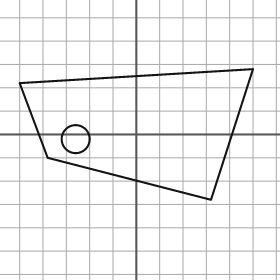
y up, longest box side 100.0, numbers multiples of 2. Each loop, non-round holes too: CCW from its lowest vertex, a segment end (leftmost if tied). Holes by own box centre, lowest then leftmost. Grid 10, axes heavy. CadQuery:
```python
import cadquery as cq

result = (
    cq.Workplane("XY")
    .moveTo(32.0, -28.0)
    .lineTo(50.0, 28.0)
    .lineTo(-50.0, 22.0)
    .lineTo(-38.0, -10.0)
    .close()
    .moveTo(-26.0, -2.0)
    .circle(6.0)
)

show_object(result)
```